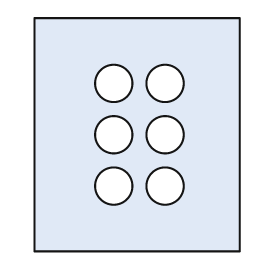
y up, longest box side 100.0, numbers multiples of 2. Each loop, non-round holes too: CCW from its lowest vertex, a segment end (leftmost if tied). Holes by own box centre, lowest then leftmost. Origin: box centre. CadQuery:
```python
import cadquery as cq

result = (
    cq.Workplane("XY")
    .moveTo(-44.0, -50.0)
    .lineTo(44.0, -50.0)
    .lineTo(44.0, 50.0)
    .lineTo(-44.0, 50.0)
    .close()
    .moveTo(-10.0, -22.0)
    .circle(8.0)
    .moveTo(12.0, -22.0)
    .circle(8.0)
    .moveTo(-10.0, 0.0)
    .circle(8.0)
    .moveTo(12.0, 0.0)
    .circle(8.0)
    .moveTo(-10.0, 22.0)
    .circle(8.0)
    .moveTo(12.0, 22.0)
    .circle(8.0)
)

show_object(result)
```